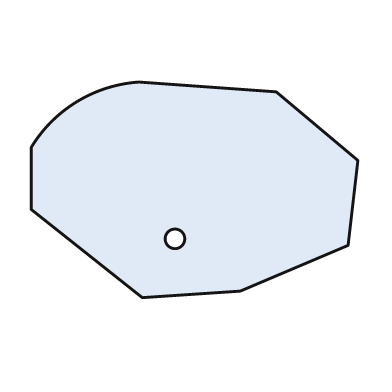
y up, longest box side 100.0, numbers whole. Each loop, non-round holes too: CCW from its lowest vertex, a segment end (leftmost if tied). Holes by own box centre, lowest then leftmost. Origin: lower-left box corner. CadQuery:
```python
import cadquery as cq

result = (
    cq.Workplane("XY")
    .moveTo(34.0, 0.0)
    .lineTo(64.0, 2.0)
    .lineTo(97.0, 16.0)
    .lineTo(100.0, 42.0)
    .lineTo(75.0, 63.0)
    .lineTo(33.0, 66.0)
    .threePointArc((14.0, 60.0), (0.0, 46.0))
    .lineTo(0.0, 27.0)
    .close()
    .moveTo(44.0, 18.0)
    .circle(3.0)
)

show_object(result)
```